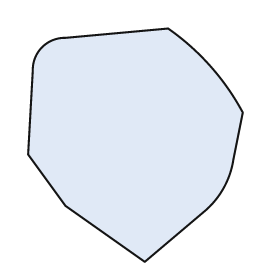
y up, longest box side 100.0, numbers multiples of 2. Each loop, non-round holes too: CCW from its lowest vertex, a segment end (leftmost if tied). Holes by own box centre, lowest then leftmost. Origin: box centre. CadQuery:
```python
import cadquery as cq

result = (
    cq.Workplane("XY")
    .moveTo(4.0, -50.0)
    .lineTo(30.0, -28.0)
    .threePointArc((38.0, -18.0), (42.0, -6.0))
    .lineTo(46.0, 14.0)
    .threePointArc((32.0, 34.0), (14.0, 50.0))
    .lineTo(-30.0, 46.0)
    .threePointArc((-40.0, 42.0), (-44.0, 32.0))
    .lineTo(-46.0, -4.0)
    .lineTo(-30.0, -26.0)
    .close()
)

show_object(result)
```